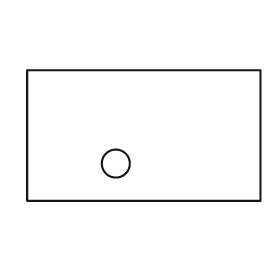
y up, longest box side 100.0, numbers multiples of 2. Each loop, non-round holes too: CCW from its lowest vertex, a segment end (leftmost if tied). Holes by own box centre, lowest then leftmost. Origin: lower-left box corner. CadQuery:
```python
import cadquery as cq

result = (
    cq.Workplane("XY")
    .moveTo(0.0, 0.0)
    .lineTo(100.0, 0.0)
    .lineTo(100.0, 56.0)
    .lineTo(0.0, 56.0)
    .close()
    .moveTo(38.0, 16.0)
    .circle(6.0)
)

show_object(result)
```